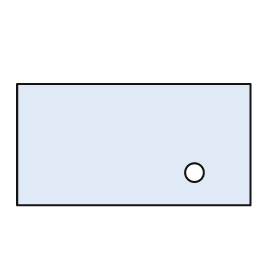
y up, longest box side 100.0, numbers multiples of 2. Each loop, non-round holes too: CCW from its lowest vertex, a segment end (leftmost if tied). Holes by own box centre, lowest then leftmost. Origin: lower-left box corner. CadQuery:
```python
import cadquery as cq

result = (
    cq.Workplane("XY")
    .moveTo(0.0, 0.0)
    .lineTo(100.0, 0.0)
    .lineTo(100.0, 52.0)
    .lineTo(0.0, 52.0)
    .close()
    .moveTo(76.0, 14.0)
    .circle(4.0)
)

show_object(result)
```